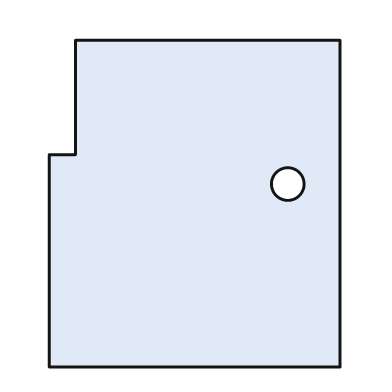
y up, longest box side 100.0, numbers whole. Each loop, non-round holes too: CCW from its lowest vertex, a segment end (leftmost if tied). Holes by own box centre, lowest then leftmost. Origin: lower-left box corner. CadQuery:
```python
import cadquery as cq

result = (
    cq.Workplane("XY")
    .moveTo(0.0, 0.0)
    .lineTo(89.0, 0.0)
    .lineTo(89.0, 100.0)
    .lineTo(8.0, 100.0)
    .lineTo(8.0, 65.0)
    .lineTo(0.0, 65.0)
    .close()
    .moveTo(73.0, 56.0)
    .circle(5.0)
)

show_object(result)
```